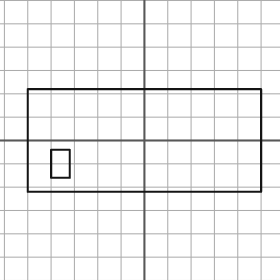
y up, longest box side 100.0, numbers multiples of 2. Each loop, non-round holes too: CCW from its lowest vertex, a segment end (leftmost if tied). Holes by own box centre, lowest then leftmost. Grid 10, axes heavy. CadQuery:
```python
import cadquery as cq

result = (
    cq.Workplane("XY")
    .moveTo(-50.0, -22.0)
    .lineTo(50.0, -22.0)
    .lineTo(50.0, 22.0)
    .lineTo(-50.0, 22.0)
    .close()
    .moveTo(-40.0, -16.0)
    .lineTo(-32.0, -16.0)
    .lineTo(-32.0, -4.0)
    .lineTo(-40.0, -4.0)
    .close()
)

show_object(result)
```